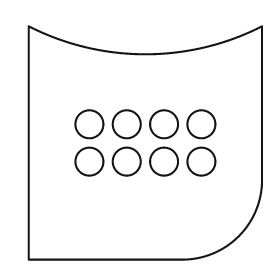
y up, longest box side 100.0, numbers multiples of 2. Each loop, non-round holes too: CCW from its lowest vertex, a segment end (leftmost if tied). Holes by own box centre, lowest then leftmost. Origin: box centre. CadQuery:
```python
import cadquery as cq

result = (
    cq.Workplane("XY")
    .moveTo(-50.0, -50.0)
    .lineTo(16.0, -50.0)
    .threePointArc((40.0, -40.0), (50.0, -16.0))
    .lineTo(50.0, 50.0)
    .threePointArc((0.0, 38.0), (-50.0, 50.0))
    .close()
    .moveTo(-24.0, -8.0)
    .circle(6.0)
    .moveTo(-8.0, -8.0)
    .circle(6.0)
    .moveTo(8.0, -8.0)
    .circle(6.0)
    .moveTo(24.0, -8.0)
    .circle(6.0)
    .moveTo(-24.0, 8.0)
    .circle(6.0)
    .moveTo(-8.0, 8.0)
    .circle(6.0)
    .moveTo(8.0, 8.0)
    .circle(6.0)
    .moveTo(24.0, 8.0)
    .circle(6.0)
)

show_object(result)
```